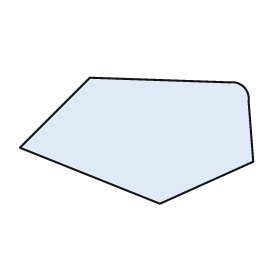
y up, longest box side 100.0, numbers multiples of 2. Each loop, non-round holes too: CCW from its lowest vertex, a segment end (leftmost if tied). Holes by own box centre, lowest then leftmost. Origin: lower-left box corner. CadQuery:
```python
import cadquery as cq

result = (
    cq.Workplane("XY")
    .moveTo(60.0, 0.0)
    .lineTo(100.0, 18.0)
    .lineTo(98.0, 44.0)
    .threePointArc((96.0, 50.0), (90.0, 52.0))
    .lineTo(30.0, 54.0)
    .lineTo(0.0, 24.0)
    .close()
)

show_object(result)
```